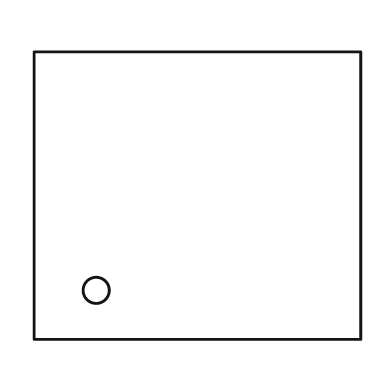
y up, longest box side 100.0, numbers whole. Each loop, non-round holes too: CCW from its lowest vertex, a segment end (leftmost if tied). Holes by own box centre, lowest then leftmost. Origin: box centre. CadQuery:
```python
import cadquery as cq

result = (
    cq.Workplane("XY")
    .moveTo(-50.0, -44.0)
    .lineTo(50.0, -44.0)
    .lineTo(50.0, 44.0)
    .lineTo(-50.0, 44.0)
    .close()
    .moveTo(-31.0, -29.0)
    .circle(4.0)
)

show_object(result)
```